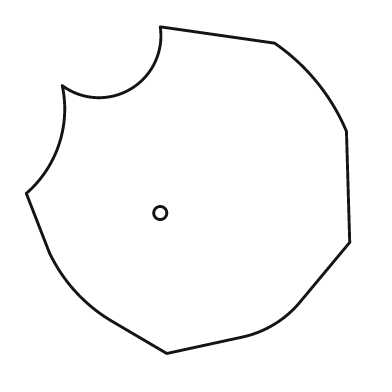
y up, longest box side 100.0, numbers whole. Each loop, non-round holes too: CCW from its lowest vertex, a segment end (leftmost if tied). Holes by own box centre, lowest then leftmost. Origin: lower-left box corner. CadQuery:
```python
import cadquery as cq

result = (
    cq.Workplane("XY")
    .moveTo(43.0, 0.0)
    .lineTo(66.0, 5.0)
    .threePointArc((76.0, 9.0), (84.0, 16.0))
    .lineTo(99.0, 34.0)
    .lineTo(98.0, 68.0)
    .threePointArc((89.0, 83.0), (76.0, 95.0))
    .lineTo(41.0, 100.0)
    .threePointArc((32.0, 81.0), (11.0, 82.0))
    .threePointArc((10.0, 64.0), (0.0, 49.0))
    .lineTo(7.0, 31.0)
    .threePointArc((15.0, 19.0), (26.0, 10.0))
    .close()
    .moveTo(41.0, 43.0)
    .circle(2.0)
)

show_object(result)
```